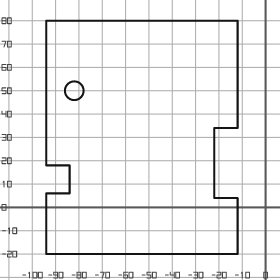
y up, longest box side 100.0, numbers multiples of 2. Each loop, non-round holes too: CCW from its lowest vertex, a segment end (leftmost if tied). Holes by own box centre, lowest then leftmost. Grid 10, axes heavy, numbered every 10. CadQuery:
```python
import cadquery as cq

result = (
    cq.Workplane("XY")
    .moveTo(-94.0, -20.0)
    .lineTo(-12.0, -20.0)
    .lineTo(-12.0, 4.0)
    .lineTo(-22.0, 4.0)
    .lineTo(-22.0, 34.0)
    .lineTo(-12.0, 34.0)
    .lineTo(-12.0, 80.0)
    .lineTo(-94.0, 80.0)
    .lineTo(-94.0, 18.0)
    .lineTo(-84.0, 18.0)
    .lineTo(-84.0, 6.0)
    .lineTo(-94.0, 6.0)
    .close()
    .moveTo(-82.0, 50.0)
    .circle(4.0)
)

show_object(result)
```